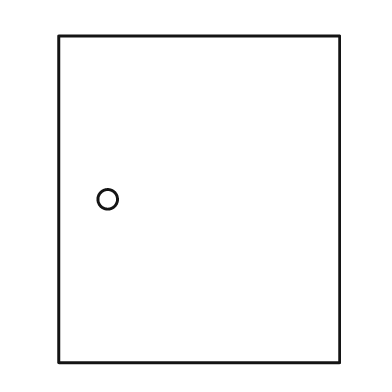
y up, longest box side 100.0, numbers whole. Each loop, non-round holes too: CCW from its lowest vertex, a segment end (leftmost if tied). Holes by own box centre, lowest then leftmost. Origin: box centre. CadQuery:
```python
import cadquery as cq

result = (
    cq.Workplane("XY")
    .moveTo(-43.0, -50.0)
    .lineTo(43.0, -50.0)
    .lineTo(43.0, 50.0)
    .lineTo(-43.0, 50.0)
    .close()
    .moveTo(-28.0, 0.0)
    .circle(3.0)
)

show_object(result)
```